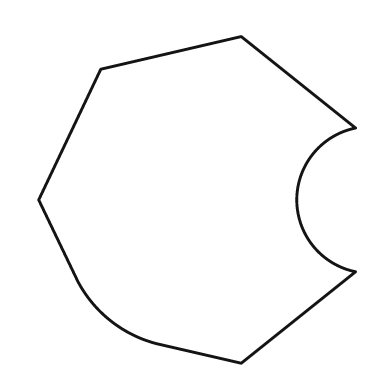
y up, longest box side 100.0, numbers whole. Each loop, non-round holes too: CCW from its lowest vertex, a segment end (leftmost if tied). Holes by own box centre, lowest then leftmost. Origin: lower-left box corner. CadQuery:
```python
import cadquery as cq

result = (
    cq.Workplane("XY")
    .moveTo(62.0, 0.0)
    .lineTo(97.0, 28.0)
    .threePointArc((79.0, 50.0), (97.0, 72.0))
    .lineTo(62.0, 100.0)
    .lineTo(19.0, 90.0)
    .lineTo(0.0, 50.0)
    .lineTo(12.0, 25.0)
    .threePointArc((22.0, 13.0), (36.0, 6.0))
    .close()
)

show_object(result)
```